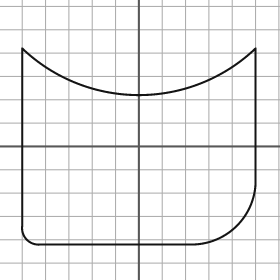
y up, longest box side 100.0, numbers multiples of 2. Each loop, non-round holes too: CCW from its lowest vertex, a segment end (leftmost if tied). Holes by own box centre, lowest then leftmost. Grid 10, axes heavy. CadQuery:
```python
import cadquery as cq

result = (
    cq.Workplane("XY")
    .moveTo(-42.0, -42.0)
    .lineTo(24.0, -42.0)
    .threePointArc((42.0, -34.0), (50.0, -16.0))
    .lineTo(50.0, 42.0)
    .threePointArc((0.0, 22.0), (-50.0, 42.0))
    .lineTo(-50.0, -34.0)
    .threePointArc((-48.0, -40.0), (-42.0, -42.0))
    .close()
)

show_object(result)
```